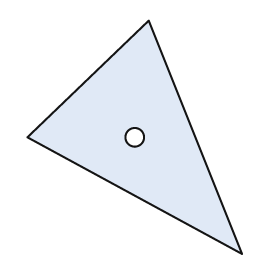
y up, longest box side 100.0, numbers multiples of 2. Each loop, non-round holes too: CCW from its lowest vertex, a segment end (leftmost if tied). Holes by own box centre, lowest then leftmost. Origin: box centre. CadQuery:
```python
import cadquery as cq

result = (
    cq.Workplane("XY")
    .moveTo(46.0, -50.0)
    .lineTo(6.0, 50.0)
    .lineTo(-46.0, 0.0)
    .close()
    .moveTo(0.0, 0.0)
    .circle(4.0)
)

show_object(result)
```